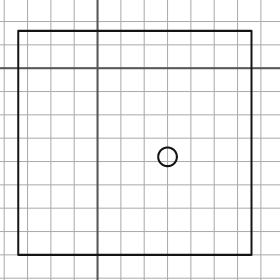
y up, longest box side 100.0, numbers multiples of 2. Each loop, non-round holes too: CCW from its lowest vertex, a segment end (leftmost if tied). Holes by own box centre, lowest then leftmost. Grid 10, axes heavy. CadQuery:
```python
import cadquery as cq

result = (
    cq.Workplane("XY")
    .moveTo(-34.0, -80.0)
    .lineTo(66.0, -80.0)
    .lineTo(66.0, 16.0)
    .lineTo(-34.0, 16.0)
    .close()
    .moveTo(30.0, -38.0)
    .circle(4.0)
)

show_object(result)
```